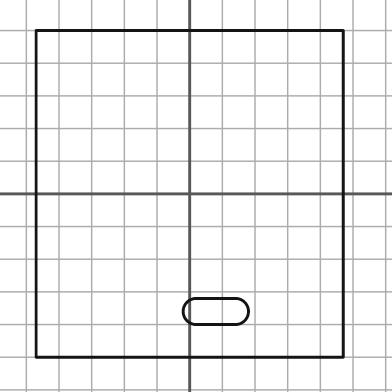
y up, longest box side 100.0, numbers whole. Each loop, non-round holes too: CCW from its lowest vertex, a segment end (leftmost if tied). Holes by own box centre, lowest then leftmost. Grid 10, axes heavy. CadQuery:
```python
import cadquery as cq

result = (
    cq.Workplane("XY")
    .moveTo(-47.0, -50.0)
    .lineTo(47.0, -50.0)
    .lineTo(47.0, 50.0)
    .lineTo(-47.0, 50.0)
    .close()
    .moveTo(2.0, -40.0)
    .lineTo(14.0, -40.0)
    .threePointArc((18.0, -36.0), (14.0, -32.0))
    .lineTo(2.0, -32.0)
    .threePointArc((-2.0, -36.0), (2.0, -40.0))
    .close()
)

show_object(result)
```